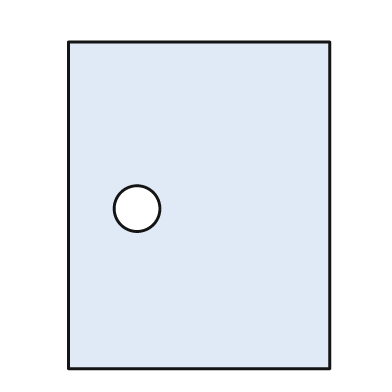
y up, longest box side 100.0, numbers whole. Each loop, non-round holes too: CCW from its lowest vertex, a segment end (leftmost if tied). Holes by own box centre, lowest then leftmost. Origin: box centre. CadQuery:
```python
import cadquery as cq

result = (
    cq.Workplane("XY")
    .moveTo(-40.0, -50.0)
    .lineTo(40.0, -50.0)
    .lineTo(40.0, 50.0)
    .lineTo(-40.0, 50.0)
    .close()
    .moveTo(-19.0, -1.0)
    .circle(7.0)
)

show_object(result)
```